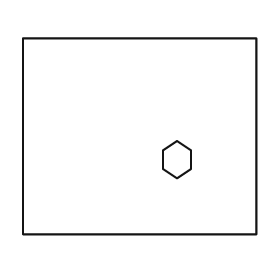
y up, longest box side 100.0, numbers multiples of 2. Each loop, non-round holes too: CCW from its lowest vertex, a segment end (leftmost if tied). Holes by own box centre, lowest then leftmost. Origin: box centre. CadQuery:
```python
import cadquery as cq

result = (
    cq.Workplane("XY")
    .moveTo(-50.0, -42.0)
    .lineTo(50.0, -42.0)
    .lineTo(50.0, 42.0)
    .lineTo(-50.0, 42.0)
    .close()
    .moveTo(16.0, -18.0)
    .lineTo(22.0, -14.0)
    .lineTo(22.0, -6.0)
    .lineTo(16.0, -2.0)
    .lineTo(10.0, -6.0)
    .lineTo(10.0, -14.0)
    .close()
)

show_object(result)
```